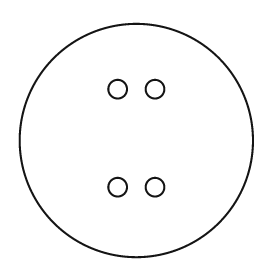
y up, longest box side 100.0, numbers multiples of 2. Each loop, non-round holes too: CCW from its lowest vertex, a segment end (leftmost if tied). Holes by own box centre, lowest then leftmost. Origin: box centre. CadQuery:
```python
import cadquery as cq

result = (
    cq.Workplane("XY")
    .moveTo(0.0, 0.0)
    .circle(50.0)
    .moveTo(-8.0, -20.0)
    .circle(4.0)
    .moveTo(8.0, -20.0)
    .circle(4.0)
    .moveTo(-8.0, 22.0)
    .circle(4.0)
    .moveTo(8.0, 22.0)
    .circle(4.0)
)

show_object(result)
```